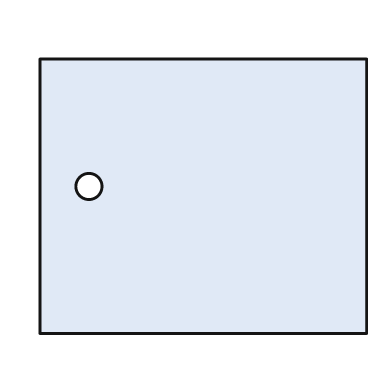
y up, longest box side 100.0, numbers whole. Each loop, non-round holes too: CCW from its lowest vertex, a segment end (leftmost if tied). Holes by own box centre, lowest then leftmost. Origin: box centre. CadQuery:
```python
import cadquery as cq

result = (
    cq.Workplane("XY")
    .moveTo(-50.0, -42.0)
    .lineTo(50.0, -42.0)
    .lineTo(50.0, 42.0)
    .lineTo(-50.0, 42.0)
    .close()
    .moveTo(-35.0, 3.0)
    .circle(4.0)
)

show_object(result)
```